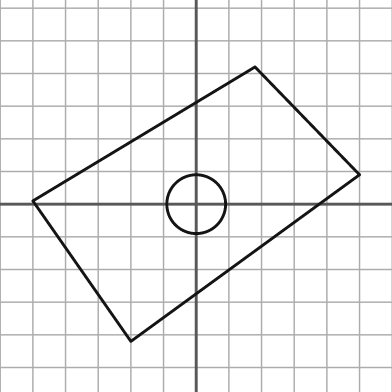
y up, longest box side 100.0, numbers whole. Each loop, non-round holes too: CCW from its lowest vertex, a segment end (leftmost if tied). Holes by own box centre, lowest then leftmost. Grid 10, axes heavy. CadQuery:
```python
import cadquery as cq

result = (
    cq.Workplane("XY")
    .moveTo(-20.0, -42.0)
    .lineTo(50.0, 9.0)
    .lineTo(18.0, 42.0)
    .lineTo(-50.0, 1.0)
    .close()
    .moveTo(0.0, 0.0)
    .circle(9.0)
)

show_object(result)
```